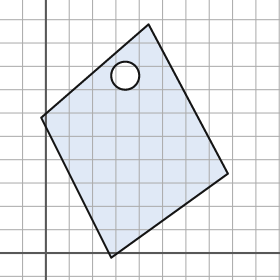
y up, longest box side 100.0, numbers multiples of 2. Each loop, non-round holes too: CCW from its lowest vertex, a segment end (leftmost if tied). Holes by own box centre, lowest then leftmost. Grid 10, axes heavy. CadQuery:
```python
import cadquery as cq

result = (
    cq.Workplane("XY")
    .moveTo(28.0, -2.0)
    .lineTo(78.0, 34.0)
    .lineTo(44.0, 98.0)
    .lineTo(-2.0, 58.0)
    .close()
    .moveTo(34.0, 76.0)
    .circle(6.0)
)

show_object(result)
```